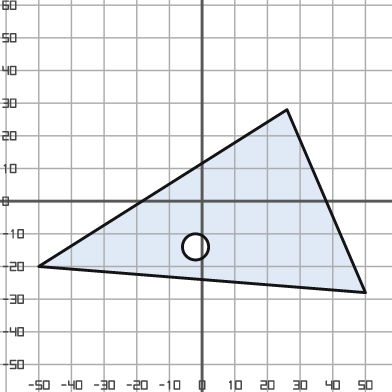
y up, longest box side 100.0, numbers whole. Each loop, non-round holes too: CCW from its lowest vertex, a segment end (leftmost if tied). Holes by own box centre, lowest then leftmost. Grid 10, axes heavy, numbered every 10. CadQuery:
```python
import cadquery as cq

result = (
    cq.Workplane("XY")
    .moveTo(50.0, -28.0)
    .lineTo(26.0, 28.0)
    .lineTo(-50.0, -20.0)
    .close()
    .moveTo(-2.0, -14.0)
    .circle(4.0)
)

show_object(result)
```